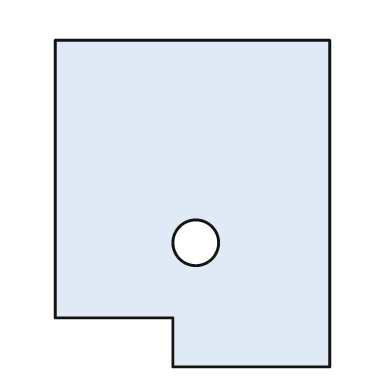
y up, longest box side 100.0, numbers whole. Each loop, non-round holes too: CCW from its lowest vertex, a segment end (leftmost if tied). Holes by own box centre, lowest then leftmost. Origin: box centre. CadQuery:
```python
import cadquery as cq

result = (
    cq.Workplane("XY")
    .moveTo(-6.0, -50.0)
    .lineTo(42.0, -50.0)
    .lineTo(42.0, 50.0)
    .lineTo(-42.0, 50.0)
    .lineTo(-42.0, -35.0)
    .lineTo(-6.0, -35.0)
    .close()
    .moveTo(1.0, -12.0)
    .circle(7.0)
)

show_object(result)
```